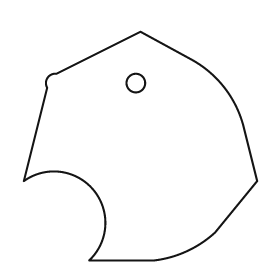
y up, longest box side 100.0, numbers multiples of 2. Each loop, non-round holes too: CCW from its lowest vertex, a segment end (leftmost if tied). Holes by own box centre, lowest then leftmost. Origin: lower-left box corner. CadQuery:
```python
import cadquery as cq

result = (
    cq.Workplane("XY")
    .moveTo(28.0, 0.0)
    .lineTo(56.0, 0.0)
    .threePointArc((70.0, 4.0), (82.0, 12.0))
    .lineTo(100.0, 34.0)
    .lineTo(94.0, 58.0)
    .threePointArc((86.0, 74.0), (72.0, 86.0))
    .lineTo(50.0, 98.0)
    .lineTo(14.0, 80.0)
    .threePointArc((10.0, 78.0), (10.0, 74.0))
    .lineTo(0.0, 34.0)
    .threePointArc((30.0, 30.0), (28.0, 0.0))
    .close()
    .moveTo(48.0, 76.0)
    .circle(4.0)
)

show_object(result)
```